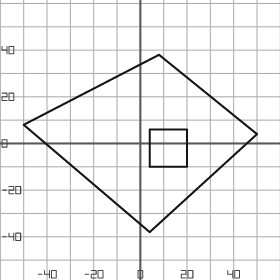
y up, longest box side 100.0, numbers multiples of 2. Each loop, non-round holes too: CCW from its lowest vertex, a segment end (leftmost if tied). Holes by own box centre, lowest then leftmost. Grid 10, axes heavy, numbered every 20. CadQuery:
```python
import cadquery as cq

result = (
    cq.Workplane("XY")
    .moveTo(4.0, -38.0)
    .lineTo(50.0, 4.0)
    .lineTo(8.0, 38.0)
    .lineTo(-50.0, 8.0)
    .close()
    .moveTo(4.0, -10.0)
    .lineTo(20.0, -10.0)
    .lineTo(20.0, 6.0)
    .lineTo(4.0, 6.0)
    .close()
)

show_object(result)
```